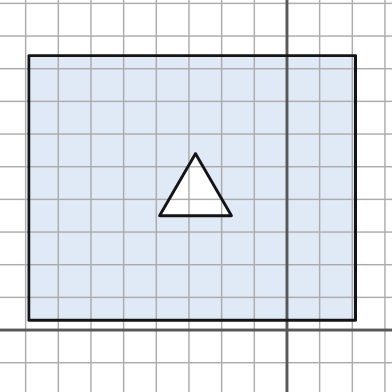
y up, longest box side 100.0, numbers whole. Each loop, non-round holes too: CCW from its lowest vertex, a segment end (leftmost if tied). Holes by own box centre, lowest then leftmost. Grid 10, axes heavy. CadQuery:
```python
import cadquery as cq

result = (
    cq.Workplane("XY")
    .moveTo(-79.0, 3.0)
    .lineTo(21.0, 3.0)
    .lineTo(21.0, 84.0)
    .lineTo(-79.0, 84.0)
    .close()
    .moveTo(-39.0, 35.0)
    .lineTo(-17.0, 35.0)
    .lineTo(-28.0, 54.0)
    .close()
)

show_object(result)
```